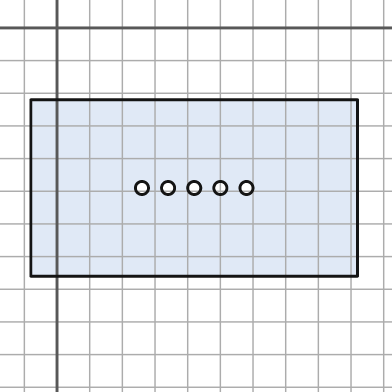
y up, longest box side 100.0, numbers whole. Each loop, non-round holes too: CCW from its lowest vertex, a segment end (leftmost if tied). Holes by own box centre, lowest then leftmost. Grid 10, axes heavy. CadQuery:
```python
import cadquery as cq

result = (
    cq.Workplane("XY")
    .moveTo(-8.0, -76.0)
    .lineTo(92.0, -76.0)
    .lineTo(92.0, -22.0)
    .lineTo(-8.0, -22.0)
    .close()
    .moveTo(26.0, -49.0)
    .circle(2.0)
    .moveTo(34.0, -49.0)
    .circle(2.0)
    .moveTo(42.0, -49.0)
    .circle(2.0)
    .moveTo(50.0, -49.0)
    .circle(2.0)
    .moveTo(58.0, -49.0)
    .circle(2.0)
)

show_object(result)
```